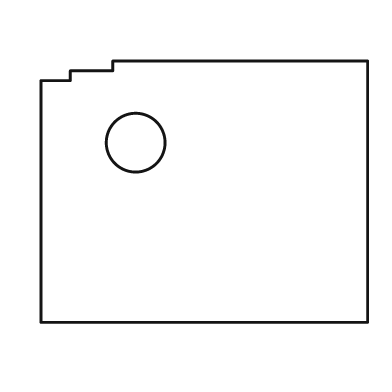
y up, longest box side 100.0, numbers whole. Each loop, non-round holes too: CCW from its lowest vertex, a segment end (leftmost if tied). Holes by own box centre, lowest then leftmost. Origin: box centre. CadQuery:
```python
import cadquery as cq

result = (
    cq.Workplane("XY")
    .moveTo(-50.0, -40.0)
    .lineTo(50.0, -40.0)
    .lineTo(50.0, 40.0)
    .lineTo(-28.0, 40.0)
    .lineTo(-28.0, 37.0)
    .lineTo(-41.0, 37.0)
    .lineTo(-41.0, 34.0)
    .lineTo(-50.0, 34.0)
    .close()
    .moveTo(-21.0, 15.0)
    .circle(9.0)
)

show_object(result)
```